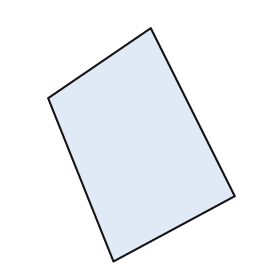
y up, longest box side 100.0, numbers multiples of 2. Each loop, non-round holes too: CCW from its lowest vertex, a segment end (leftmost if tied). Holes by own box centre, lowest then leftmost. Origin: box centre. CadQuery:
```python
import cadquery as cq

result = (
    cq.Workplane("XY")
    .moveTo(-12.0, -50.0)
    .lineTo(40.0, -22.0)
    .lineTo(4.0, 50.0)
    .lineTo(-40.0, 20.0)
    .close()
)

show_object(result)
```